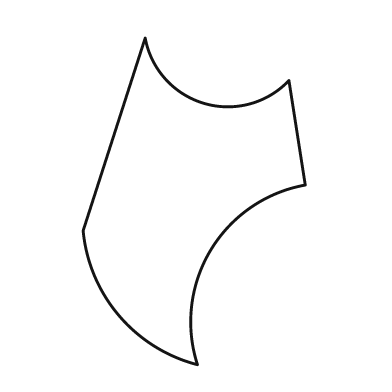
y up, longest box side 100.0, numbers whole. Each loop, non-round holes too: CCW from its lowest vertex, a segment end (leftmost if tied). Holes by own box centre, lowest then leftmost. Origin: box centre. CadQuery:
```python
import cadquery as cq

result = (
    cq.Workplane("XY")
    .moveTo(1.0, -50.0)
    .threePointArc((5.0, -15.0), (34.0, 5.0))
    .lineTo(29.0, 37.0)
    .threePointArc((3.0, 30.0), (-15.0, 50.0))
    .lineTo(-34.0, -9.0)
    .threePointArc((-23.0, -35.0), (1.0, -50.0))
    .close()
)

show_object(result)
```